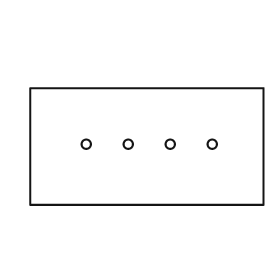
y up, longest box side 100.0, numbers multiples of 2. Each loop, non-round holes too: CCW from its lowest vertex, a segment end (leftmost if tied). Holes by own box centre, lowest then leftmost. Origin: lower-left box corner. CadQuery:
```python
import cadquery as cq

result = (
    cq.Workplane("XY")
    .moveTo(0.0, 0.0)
    .lineTo(100.0, 0.0)
    .lineTo(100.0, 50.0)
    .lineTo(0.0, 50.0)
    .close()
    .moveTo(24.0, 26.0)
    .circle(2.0)
    .moveTo(42.0, 26.0)
    .circle(2.0)
    .moveTo(60.0, 26.0)
    .circle(2.0)
    .moveTo(78.0, 26.0)
    .circle(2.0)
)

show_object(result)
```